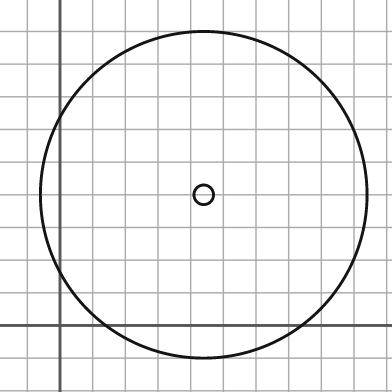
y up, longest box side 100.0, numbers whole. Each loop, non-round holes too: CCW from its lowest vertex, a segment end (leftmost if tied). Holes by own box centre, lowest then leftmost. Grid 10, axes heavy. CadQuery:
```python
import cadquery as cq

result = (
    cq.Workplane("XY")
    .moveTo(44.0, 40.0)
    .circle(50.0)
    .moveTo(44.0, 40.0)
    .circle(3.0)
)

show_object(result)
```